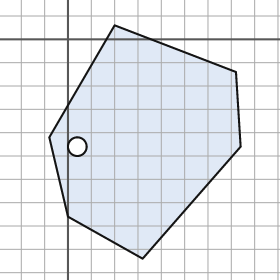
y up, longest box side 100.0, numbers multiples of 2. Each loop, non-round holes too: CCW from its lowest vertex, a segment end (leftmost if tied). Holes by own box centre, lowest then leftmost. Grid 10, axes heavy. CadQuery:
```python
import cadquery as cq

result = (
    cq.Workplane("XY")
    .moveTo(32.0, -94.0)
    .lineTo(74.0, -46.0)
    .lineTo(72.0, -14.0)
    .lineTo(20.0, 6.0)
    .lineTo(-8.0, -42.0)
    .lineTo(0.0, -76.0)
    .close()
    .moveTo(4.0, -46.0)
    .circle(4.0)
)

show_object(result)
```